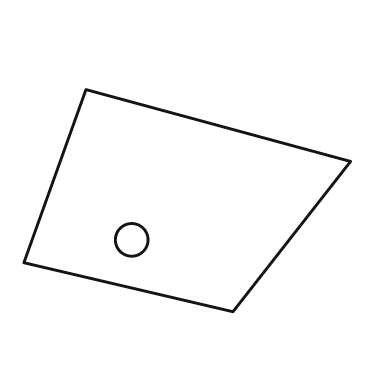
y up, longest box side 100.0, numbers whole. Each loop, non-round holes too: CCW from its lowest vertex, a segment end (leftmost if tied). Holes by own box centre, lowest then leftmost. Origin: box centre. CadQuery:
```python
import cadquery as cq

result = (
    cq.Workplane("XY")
    .moveTo(14.0, -34.0)
    .lineTo(50.0, 12.0)
    .lineTo(-31.0, 34.0)
    .lineTo(-50.0, -19.0)
    .close()
    .moveTo(-17.0, -12.0)
    .circle(5.0)
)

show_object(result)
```